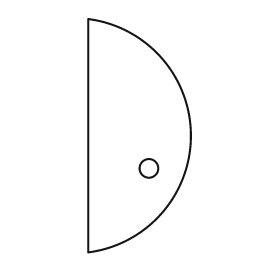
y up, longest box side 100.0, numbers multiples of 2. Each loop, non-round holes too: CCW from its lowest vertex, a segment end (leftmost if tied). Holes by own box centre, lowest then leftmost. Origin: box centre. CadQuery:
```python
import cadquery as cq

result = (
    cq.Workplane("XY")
    .moveTo(-22.0, -50.0)
    .threePointArc((22.0, 0.0), (-22.0, 50.0))
    .close()
    .moveTo(4.0, -14.0)
    .circle(4.0)
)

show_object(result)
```